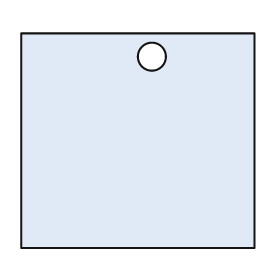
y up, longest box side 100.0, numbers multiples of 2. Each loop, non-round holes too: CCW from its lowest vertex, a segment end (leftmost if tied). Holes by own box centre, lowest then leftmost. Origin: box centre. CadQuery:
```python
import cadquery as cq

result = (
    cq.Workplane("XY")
    .moveTo(-50.0, -46.0)
    .lineTo(50.0, -46.0)
    .lineTo(50.0, 46.0)
    .lineTo(-50.0, 46.0)
    .close()
    .moveTo(6.0, 36.0)
    .circle(6.0)
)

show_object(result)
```